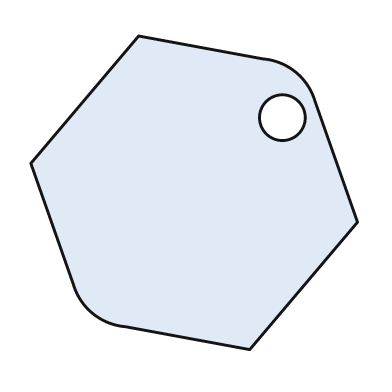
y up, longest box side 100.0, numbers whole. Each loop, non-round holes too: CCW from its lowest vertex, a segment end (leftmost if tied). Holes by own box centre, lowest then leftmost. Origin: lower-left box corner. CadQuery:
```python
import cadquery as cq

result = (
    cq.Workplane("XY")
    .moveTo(67.0, 0.0)
    .lineTo(100.0, 39.0)
    .lineTo(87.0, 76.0)
    .threePointArc((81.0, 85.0), (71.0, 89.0))
    .lineTo(33.0, 96.0)
    .lineTo(0.0, 57.0)
    .lineTo(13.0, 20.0)
    .threePointArc((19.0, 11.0), (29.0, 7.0))
    .close()
    .moveTo(77.0, 71.0)
    .circle(7.0)
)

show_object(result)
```